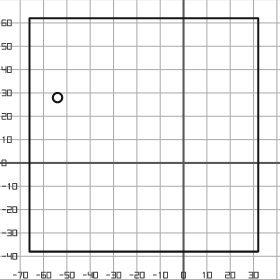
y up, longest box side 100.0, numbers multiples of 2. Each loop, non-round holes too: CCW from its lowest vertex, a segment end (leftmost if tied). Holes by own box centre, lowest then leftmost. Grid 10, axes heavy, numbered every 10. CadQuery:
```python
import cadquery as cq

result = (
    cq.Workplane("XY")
    .moveTo(-66.0, -38.0)
    .lineTo(32.0, -38.0)
    .lineTo(32.0, 62.0)
    .lineTo(-66.0, 62.0)
    .close()
    .moveTo(-54.0, 28.0)
    .circle(2.0)
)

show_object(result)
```